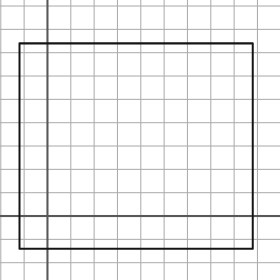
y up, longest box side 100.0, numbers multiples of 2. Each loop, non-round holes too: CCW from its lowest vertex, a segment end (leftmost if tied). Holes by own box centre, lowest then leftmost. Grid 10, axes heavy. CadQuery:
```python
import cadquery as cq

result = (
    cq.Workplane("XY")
    .moveTo(-12.0, -14.0)
    .lineTo(88.0, -14.0)
    .lineTo(88.0, 74.0)
    .lineTo(-12.0, 74.0)
    .close()
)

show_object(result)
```